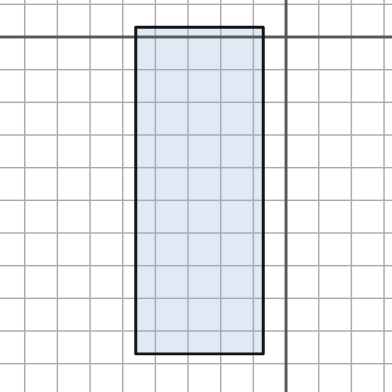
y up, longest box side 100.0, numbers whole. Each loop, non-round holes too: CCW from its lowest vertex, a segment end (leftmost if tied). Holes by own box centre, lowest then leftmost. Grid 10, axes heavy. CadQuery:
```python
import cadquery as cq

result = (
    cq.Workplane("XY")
    .moveTo(-46.0, -97.0)
    .lineTo(-7.0, -97.0)
    .lineTo(-7.0, 3.0)
    .lineTo(-46.0, 3.0)
    .close()
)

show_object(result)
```